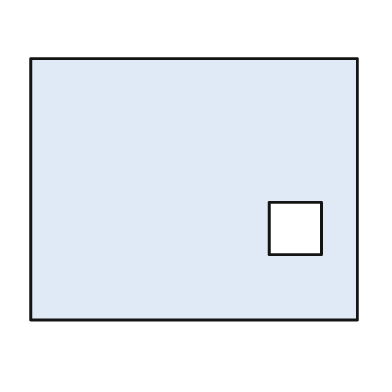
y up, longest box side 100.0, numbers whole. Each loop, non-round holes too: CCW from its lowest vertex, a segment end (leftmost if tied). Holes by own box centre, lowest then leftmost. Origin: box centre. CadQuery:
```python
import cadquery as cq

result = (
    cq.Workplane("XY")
    .moveTo(-50.0, -40.0)
    .lineTo(50.0, -40.0)
    .lineTo(50.0, 40.0)
    .lineTo(-50.0, 40.0)
    .close()
    .moveTo(23.0, -20.0)
    .lineTo(39.0, -20.0)
    .lineTo(39.0, -4.0)
    .lineTo(23.0, -4.0)
    .close()
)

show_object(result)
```